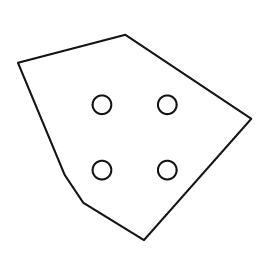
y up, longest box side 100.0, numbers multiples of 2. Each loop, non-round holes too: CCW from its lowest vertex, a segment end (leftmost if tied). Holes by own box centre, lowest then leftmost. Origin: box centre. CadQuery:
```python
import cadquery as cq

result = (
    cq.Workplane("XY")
    .moveTo(4.0, -44.0)
    .lineTo(50.0, 8.0)
    .lineTo(-4.0, 44.0)
    .lineTo(-50.0, 32.0)
    .lineTo(-30.0, -16.0)
    .lineTo(-22.0, -28.0)
    .close()
    .moveTo(-14.0, -14.0)
    .circle(4.0)
    .moveTo(14.0, -14.0)
    .circle(4.0)
    .moveTo(-14.0, 14.0)
    .circle(4.0)
    .moveTo(14.0, 14.0)
    .circle(4.0)
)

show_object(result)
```